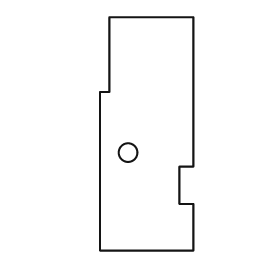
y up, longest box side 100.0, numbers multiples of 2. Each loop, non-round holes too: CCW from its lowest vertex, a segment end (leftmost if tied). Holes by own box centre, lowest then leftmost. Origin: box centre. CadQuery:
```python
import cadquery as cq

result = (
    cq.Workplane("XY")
    .moveTo(-20.0, -50.0)
    .lineTo(20.0, -50.0)
    .lineTo(20.0, -30.0)
    .lineTo(14.0, -30.0)
    .lineTo(14.0, -14.0)
    .lineTo(20.0, -14.0)
    .lineTo(20.0, 50.0)
    .lineTo(-16.0, 50.0)
    .lineTo(-16.0, 18.0)
    .lineTo(-20.0, 18.0)
    .close()
    .moveTo(-8.0, -8.0)
    .circle(4.0)
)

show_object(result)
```